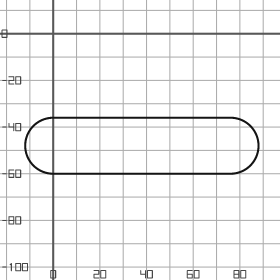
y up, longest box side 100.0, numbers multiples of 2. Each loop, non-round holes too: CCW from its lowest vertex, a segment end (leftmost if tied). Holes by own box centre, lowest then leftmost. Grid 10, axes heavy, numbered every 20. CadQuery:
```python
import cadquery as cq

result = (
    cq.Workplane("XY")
    .moveTo(0.0, -60.0)
    .lineTo(76.0, -60.0)
    .threePointArc((88.0, -48.0), (76.0, -36.0))
    .lineTo(0.0, -36.0)
    .threePointArc((-12.0, -48.0), (0.0, -60.0))
    .close()
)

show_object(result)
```